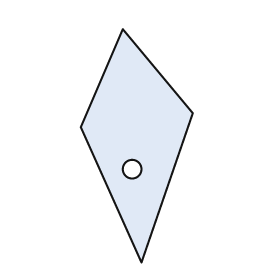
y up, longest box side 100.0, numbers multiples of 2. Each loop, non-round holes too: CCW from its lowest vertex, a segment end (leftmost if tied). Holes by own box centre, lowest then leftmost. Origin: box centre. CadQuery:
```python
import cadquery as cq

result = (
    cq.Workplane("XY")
    .moveTo(2.0, -50.0)
    .lineTo(24.0, 14.0)
    .lineTo(-6.0, 50.0)
    .lineTo(-24.0, 8.0)
    .close()
    .moveTo(-2.0, -10.0)
    .circle(4.0)
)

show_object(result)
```